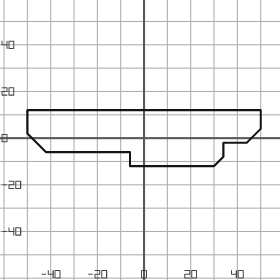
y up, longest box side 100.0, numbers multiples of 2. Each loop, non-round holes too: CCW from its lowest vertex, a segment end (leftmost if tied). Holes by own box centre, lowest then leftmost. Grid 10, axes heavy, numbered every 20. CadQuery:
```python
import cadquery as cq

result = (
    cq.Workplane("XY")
    .moveTo(-6.0, -12.0)
    .lineTo(30.0, -12.0)
    .lineTo(34.0, -8.0)
    .lineTo(34.0, -2.0)
    .lineTo(44.0, -2.0)
    .lineTo(50.0, 4.0)
    .lineTo(50.0, 12.0)
    .lineTo(-50.0, 12.0)
    .lineTo(-50.0, 2.0)
    .lineTo(-42.0, -6.0)
    .lineTo(-6.0, -6.0)
    .close()
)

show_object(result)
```